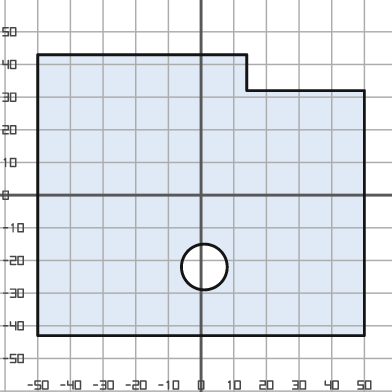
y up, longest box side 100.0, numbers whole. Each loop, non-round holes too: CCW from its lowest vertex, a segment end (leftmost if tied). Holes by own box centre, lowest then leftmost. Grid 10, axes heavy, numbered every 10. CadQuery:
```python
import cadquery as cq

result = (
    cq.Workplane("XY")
    .moveTo(-50.0, -43.0)
    .lineTo(50.0, -43.0)
    .lineTo(50.0, 32.0)
    .lineTo(14.0, 32.0)
    .lineTo(14.0, 43.0)
    .lineTo(-50.0, 43.0)
    .close()
    .moveTo(1.0, -22.0)
    .circle(7.0)
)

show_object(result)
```